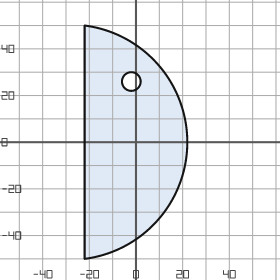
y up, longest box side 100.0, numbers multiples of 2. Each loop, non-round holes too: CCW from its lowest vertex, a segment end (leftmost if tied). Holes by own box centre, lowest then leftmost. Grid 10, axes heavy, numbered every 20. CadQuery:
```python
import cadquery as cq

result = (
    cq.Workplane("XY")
    .moveTo(-22.0, -50.0)
    .threePointArc((22.0, 0.0), (-22.0, 50.0))
    .close()
    .moveTo(-2.0, 26.0)
    .circle(4.0)
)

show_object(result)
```